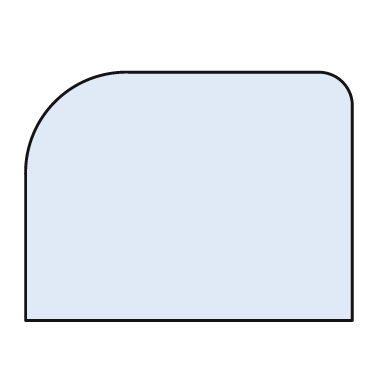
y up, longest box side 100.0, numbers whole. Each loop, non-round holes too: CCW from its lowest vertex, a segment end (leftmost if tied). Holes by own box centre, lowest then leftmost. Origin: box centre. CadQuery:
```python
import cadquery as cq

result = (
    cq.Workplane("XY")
    .moveTo(-50.0, -38.0)
    .lineTo(50.0, -38.0)
    .lineTo(50.0, 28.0)
    .threePointArc((47.0, 35.0), (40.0, 38.0))
    .lineTo(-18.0, 38.0)
    .threePointArc((-41.0, 29.0), (-50.0, 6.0))
    .close()
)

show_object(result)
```